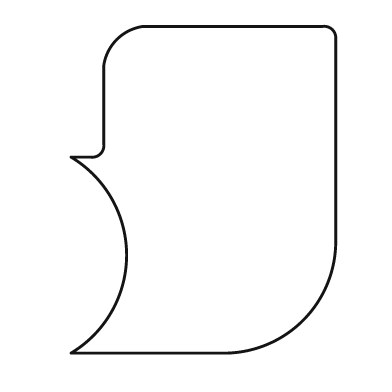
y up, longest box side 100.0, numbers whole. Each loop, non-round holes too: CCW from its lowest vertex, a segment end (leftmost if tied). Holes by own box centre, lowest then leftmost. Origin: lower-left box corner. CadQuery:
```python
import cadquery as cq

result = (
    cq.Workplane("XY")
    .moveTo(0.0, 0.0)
    .lineTo(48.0, 0.0)
    .threePointArc((71.0, 10.0), (81.0, 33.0))
    .lineTo(81.0, 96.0)
    .threePointArc((80.0, 99.0), (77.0, 100.0))
    .lineTo(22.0, 100.0)
    .threePointArc((14.0, 96.0), (10.0, 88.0))
    .lineTo(10.0, 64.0)
    .threePointArc((9.0, 61.0), (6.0, 60.0))
    .lineTo(0.0, 60.0)
    .threePointArc((17.0, 30.0), (0.0, 0.0))
    .close()
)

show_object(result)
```